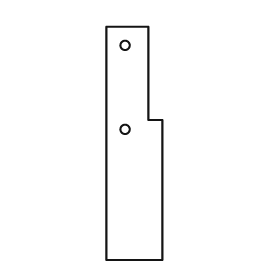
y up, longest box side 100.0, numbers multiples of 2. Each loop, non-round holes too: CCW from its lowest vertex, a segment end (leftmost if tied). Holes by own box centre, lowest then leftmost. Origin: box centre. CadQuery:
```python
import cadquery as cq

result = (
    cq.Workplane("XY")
    .moveTo(-12.0, -50.0)
    .lineTo(12.0, -50.0)
    .lineTo(12.0, 10.0)
    .lineTo(6.0, 10.0)
    .lineTo(6.0, 50.0)
    .lineTo(-12.0, 50.0)
    .close()
    .moveTo(-4.0, 6.0)
    .circle(2.0)
    .moveTo(-4.0, 42.0)
    .circle(2.0)
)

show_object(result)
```